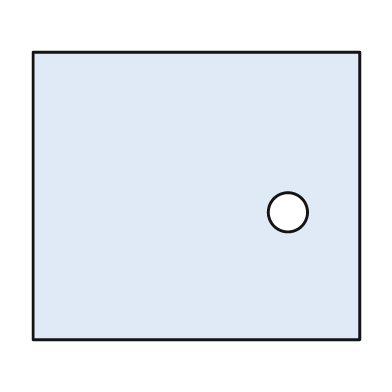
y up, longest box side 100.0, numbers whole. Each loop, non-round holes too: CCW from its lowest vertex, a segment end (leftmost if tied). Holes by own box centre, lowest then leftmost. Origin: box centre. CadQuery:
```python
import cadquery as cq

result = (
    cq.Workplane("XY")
    .moveTo(-50.0, -44.0)
    .lineTo(50.0, -44.0)
    .lineTo(50.0, 44.0)
    .lineTo(-50.0, 44.0)
    .close()
    .moveTo(28.0, -5.0)
    .circle(6.0)
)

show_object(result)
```